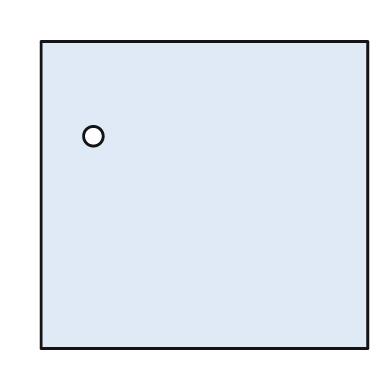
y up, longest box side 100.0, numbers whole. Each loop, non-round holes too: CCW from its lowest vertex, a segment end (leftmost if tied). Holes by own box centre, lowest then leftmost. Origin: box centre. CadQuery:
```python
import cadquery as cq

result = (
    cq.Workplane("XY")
    .moveTo(-50.0, -47.0)
    .lineTo(50.0, -47.0)
    .lineTo(50.0, 47.0)
    .lineTo(-50.0, 47.0)
    .close()
    .moveTo(-34.0, 18.0)
    .circle(3.0)
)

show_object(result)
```